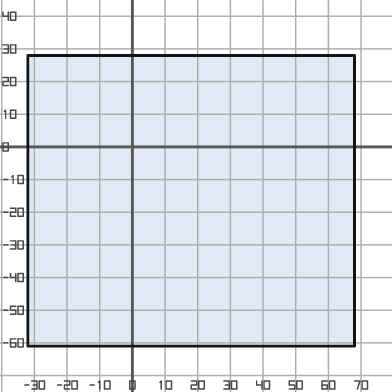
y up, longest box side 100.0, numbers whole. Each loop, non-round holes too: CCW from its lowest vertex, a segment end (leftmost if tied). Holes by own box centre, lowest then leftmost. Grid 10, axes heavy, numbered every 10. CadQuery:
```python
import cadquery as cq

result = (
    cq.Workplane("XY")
    .moveTo(-32.0, -61.0)
    .lineTo(68.0, -61.0)
    .lineTo(68.0, 28.0)
    .lineTo(-32.0, 28.0)
    .close()
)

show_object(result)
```